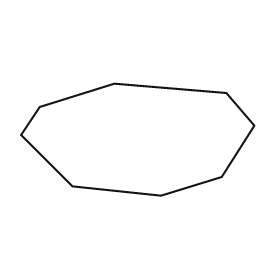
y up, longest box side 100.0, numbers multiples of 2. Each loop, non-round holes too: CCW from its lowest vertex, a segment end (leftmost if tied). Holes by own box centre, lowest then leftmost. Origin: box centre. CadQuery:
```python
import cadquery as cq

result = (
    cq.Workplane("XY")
    .moveTo(10.0, -24.0)
    .lineTo(36.0, -16.0)
    .lineTo(50.0, 6.0)
    .lineTo(38.0, 20.0)
    .lineTo(-10.0, 24.0)
    .lineTo(-42.0, 14.0)
    .lineTo(-50.0, 2.0)
    .lineTo(-28.0, -20.0)
    .close()
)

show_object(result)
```